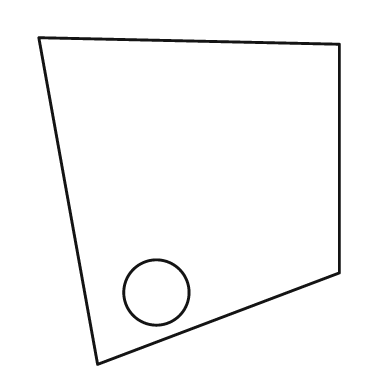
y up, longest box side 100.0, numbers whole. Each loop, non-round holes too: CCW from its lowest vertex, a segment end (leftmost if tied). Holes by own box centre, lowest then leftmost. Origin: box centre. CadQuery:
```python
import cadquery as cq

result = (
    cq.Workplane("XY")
    .moveTo(-28.0, -50.0)
    .lineTo(46.0, -22.0)
    .lineTo(46.0, 48.0)
    .lineTo(-46.0, 50.0)
    .close()
    .moveTo(-10.0, -28.0)
    .circle(10.0)
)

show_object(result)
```